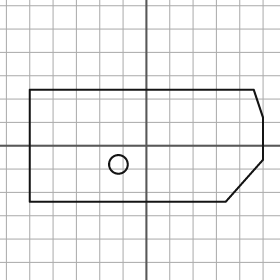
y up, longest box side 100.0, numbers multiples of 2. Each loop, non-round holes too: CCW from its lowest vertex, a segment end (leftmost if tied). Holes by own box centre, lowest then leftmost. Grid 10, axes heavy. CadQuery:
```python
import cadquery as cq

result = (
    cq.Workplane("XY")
    .moveTo(-50.0, -24.0)
    .lineTo(34.0, -24.0)
    .lineTo(50.0, -6.0)
    .lineTo(50.0, 12.0)
    .lineTo(46.0, 24.0)
    .lineTo(-50.0, 24.0)
    .close()
    .moveTo(-12.0, -8.0)
    .circle(4.0)
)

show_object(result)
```